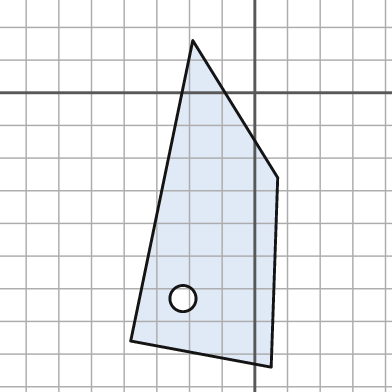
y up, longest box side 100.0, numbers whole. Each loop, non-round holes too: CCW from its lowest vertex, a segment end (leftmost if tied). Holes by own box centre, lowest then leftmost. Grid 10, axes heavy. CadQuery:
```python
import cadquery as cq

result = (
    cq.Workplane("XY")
    .moveTo(5.0, -84.0)
    .lineTo(7.0, -26.0)
    .lineTo(-19.0, 16.0)
    .lineTo(-38.0, -76.0)
    .close()
    .moveTo(-22.0, -63.0)
    .circle(4.0)
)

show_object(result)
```